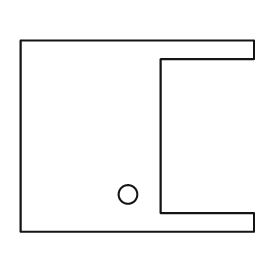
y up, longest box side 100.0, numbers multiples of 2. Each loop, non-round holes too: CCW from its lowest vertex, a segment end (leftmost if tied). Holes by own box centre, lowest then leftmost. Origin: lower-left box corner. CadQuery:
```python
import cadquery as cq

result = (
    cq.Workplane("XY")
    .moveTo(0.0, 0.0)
    .lineTo(100.0, 0.0)
    .lineTo(100.0, 8.0)
    .lineTo(60.0, 8.0)
    .lineTo(60.0, 74.0)
    .lineTo(100.0, 74.0)
    .lineTo(100.0, 82.0)
    .lineTo(0.0, 82.0)
    .close()
    .moveTo(46.0, 16.0)
    .circle(4.0)
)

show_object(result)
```